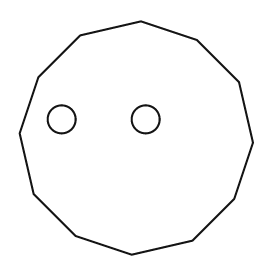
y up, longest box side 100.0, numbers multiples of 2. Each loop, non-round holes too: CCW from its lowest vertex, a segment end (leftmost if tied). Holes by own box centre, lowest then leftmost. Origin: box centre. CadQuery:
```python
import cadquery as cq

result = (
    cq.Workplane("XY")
    .moveTo(-2.0, -50.0)
    .lineTo(24.0, -44.0)
    .lineTo(42.0, -26.0)
    .lineTo(50.0, -2.0)
    .lineTo(44.0, 24.0)
    .lineTo(26.0, 42.0)
    .lineTo(2.0, 50.0)
    .lineTo(-24.0, 44.0)
    .lineTo(-42.0, 26.0)
    .lineTo(-50.0, 2.0)
    .lineTo(-44.0, -24.0)
    .lineTo(-26.0, -42.0)
    .close()
    .moveTo(-32.0, 8.0)
    .circle(6.0)
    .moveTo(4.0, 8.0)
    .circle(6.0)
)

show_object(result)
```